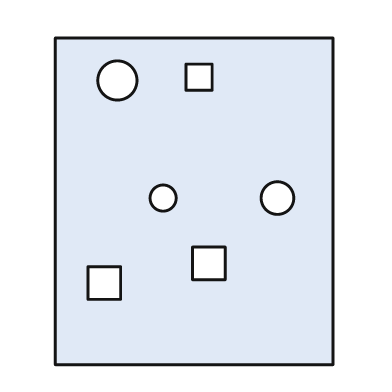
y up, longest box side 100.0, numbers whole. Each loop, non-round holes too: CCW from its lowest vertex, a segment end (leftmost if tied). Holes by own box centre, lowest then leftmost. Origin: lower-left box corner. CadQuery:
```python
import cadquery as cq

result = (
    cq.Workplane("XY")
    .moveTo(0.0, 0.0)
    .lineTo(85.0, 0.0)
    .lineTo(85.0, 100.0)
    .lineTo(0.0, 100.0)
    .close()
    .moveTo(10.0, 20.0)
    .lineTo(20.0, 20.0)
    .lineTo(20.0, 30.0)
    .lineTo(10.0, 30.0)
    .close()
    .moveTo(42.0, 26.0)
    .lineTo(52.0, 26.0)
    .lineTo(52.0, 36.0)
    .lineTo(42.0, 36.0)
    .close()
    .moveTo(33.0, 51.0)
    .circle(4.0)
    .moveTo(68.0, 51.0)
    .circle(5.0)
    .moveTo(19.0, 87.0)
    .circle(6.0)
    .moveTo(40.0, 84.0)
    .lineTo(48.0, 84.0)
    .lineTo(48.0, 92.0)
    .lineTo(40.0, 92.0)
    .close()
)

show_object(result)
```